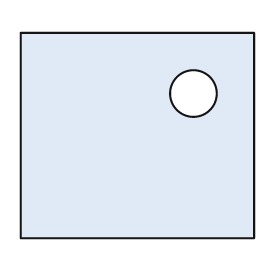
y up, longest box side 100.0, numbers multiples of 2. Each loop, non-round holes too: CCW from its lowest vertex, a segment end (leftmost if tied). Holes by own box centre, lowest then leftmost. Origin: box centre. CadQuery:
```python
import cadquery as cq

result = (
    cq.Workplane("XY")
    .moveTo(-50.0, -44.0)
    .lineTo(50.0, -44.0)
    .lineTo(50.0, 44.0)
    .lineTo(-50.0, 44.0)
    .close()
    .moveTo(24.0, 18.0)
    .circle(10.0)
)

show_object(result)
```